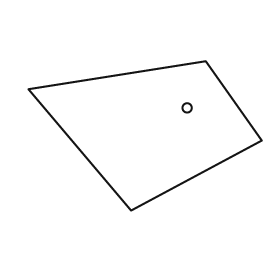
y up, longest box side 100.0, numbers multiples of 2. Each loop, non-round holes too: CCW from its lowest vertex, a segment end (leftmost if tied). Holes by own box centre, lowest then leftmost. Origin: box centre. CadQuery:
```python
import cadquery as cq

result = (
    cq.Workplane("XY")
    .moveTo(-6.0, -32.0)
    .lineTo(50.0, -2.0)
    .lineTo(26.0, 32.0)
    .lineTo(-50.0, 20.0)
    .close()
    .moveTo(18.0, 12.0)
    .circle(2.0)
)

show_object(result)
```